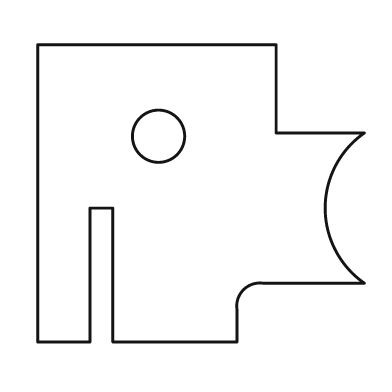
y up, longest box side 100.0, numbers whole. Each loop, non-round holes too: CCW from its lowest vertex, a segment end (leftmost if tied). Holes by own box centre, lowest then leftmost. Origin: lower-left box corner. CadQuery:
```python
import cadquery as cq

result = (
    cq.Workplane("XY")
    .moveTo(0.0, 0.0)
    .lineTo(16.0, 0.0)
    .lineTo(16.0, 41.0)
    .lineTo(23.0, 41.0)
    .lineTo(23.0, 0.0)
    .lineTo(61.0, 0.0)
    .lineTo(61.0, 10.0)
    .threePointArc((63.0, 16.0), (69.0, 18.0))
    .lineTo(100.0, 18.0)
    .threePointArc((88.0, 41.0), (100.0, 64.0))
    .lineTo(73.0, 64.0)
    .lineTo(73.0, 91.0)
    .lineTo(0.0, 91.0)
    .close()
    .moveTo(37.0, 63.0)
    .circle(8.0)
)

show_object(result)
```